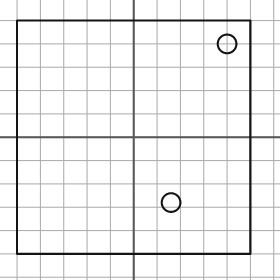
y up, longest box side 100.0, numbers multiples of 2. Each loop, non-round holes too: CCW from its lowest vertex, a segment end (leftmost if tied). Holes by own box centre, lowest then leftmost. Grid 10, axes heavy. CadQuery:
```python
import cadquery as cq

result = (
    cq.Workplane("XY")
    .moveTo(-50.0, -50.0)
    .lineTo(50.0, -50.0)
    .lineTo(50.0, 50.0)
    .lineTo(-50.0, 50.0)
    .close()
    .moveTo(16.0, -28.0)
    .circle(4.0)
    .moveTo(40.0, 40.0)
    .circle(4.0)
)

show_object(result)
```